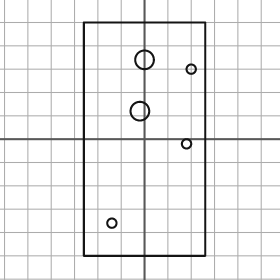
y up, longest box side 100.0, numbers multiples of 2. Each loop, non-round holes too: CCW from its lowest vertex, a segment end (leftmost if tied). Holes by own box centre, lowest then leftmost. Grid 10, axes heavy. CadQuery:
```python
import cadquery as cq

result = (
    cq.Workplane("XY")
    .moveTo(-26.0, -50.0)
    .lineTo(26.0, -50.0)
    .lineTo(26.0, 50.0)
    .lineTo(-26.0, 50.0)
    .close()
    .moveTo(-14.0, -36.0)
    .circle(2.0)
    .moveTo(18.0, -2.0)
    .circle(2.0)
    .moveTo(-2.0, 12.0)
    .circle(4.0)
    .moveTo(20.0, 30.0)
    .circle(2.0)
    .moveTo(0.0, 34.0)
    .circle(4.0)
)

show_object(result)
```